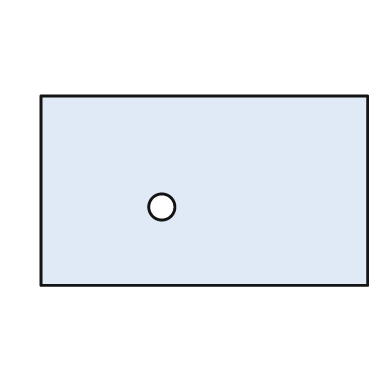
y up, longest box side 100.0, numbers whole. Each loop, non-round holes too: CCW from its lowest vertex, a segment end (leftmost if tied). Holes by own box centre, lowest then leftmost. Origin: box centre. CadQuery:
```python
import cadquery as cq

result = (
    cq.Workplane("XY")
    .moveTo(-50.0, -29.0)
    .lineTo(50.0, -29.0)
    .lineTo(50.0, 29.0)
    .lineTo(-50.0, 29.0)
    .close()
    .moveTo(-13.0, -5.0)
    .circle(4.0)
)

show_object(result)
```